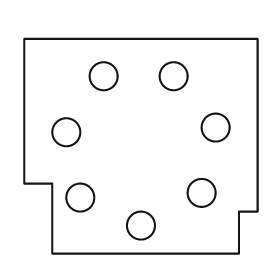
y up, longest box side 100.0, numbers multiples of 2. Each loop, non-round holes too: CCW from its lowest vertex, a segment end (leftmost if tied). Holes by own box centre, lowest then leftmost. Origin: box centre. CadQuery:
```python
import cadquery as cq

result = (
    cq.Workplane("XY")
    .moveTo(-38.0, -46.0)
    .lineTo(42.0, -46.0)
    .lineTo(42.0, -28.0)
    .lineTo(50.0, -28.0)
    .lineTo(50.0, 46.0)
    .lineTo(-50.0, 46.0)
    .lineTo(-50.0, -16.0)
    .lineTo(-38.0, -16.0)
    .close()
    .moveTo(0.0, -34.0)
    .circle(6.0)
    .moveTo(-26.0, -22.0)
    .circle(6.0)
    .moveTo(26.0, -20.0)
    .circle(6.0)
    .moveTo(-32.0, 6.0)
    .circle(6.0)
    .moveTo(32.0, 8.0)
    .circle(6.0)
    .moveTo(-16.0, 30.0)
    .circle(6.0)
    .moveTo(14.0, 30.0)
    .circle(6.0)
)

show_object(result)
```